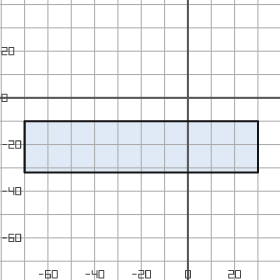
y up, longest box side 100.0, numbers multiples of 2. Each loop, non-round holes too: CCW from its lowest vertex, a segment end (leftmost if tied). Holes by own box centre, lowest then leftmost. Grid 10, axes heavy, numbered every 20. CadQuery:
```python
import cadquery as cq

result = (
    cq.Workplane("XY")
    .moveTo(-70.0, -32.0)
    .lineTo(30.0, -32.0)
    .lineTo(30.0, -10.0)
    .lineTo(-70.0, -10.0)
    .close()
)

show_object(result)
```